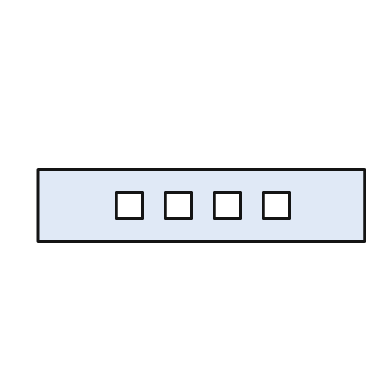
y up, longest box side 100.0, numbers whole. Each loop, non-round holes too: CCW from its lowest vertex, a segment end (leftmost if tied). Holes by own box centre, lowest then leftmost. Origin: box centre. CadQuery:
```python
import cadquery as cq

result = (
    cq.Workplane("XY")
    .moveTo(-50.0, -11.0)
    .lineTo(50.0, -11.0)
    .lineTo(50.0, 11.0)
    .lineTo(-50.0, 11.0)
    .close()
    .moveTo(-26.0, -4.0)
    .lineTo(-18.0, -4.0)
    .lineTo(-18.0, 4.0)
    .lineTo(-26.0, 4.0)
    .close()
    .moveTo(-11.0, -4.0)
    .lineTo(-3.0, -4.0)
    .lineTo(-3.0, 4.0)
    .lineTo(-11.0, 4.0)
    .close()
    .moveTo(4.0, -4.0)
    .lineTo(12.0, -4.0)
    .lineTo(12.0, 4.0)
    .lineTo(4.0, 4.0)
    .close()
    .moveTo(19.0, -4.0)
    .lineTo(27.0, -4.0)
    .lineTo(27.0, 4.0)
    .lineTo(19.0, 4.0)
    .close()
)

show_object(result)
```